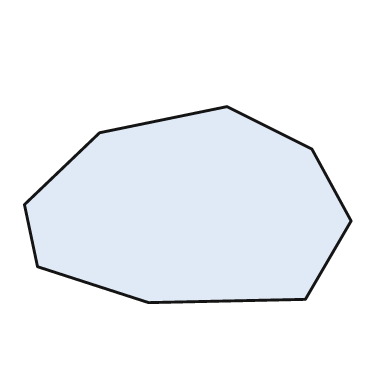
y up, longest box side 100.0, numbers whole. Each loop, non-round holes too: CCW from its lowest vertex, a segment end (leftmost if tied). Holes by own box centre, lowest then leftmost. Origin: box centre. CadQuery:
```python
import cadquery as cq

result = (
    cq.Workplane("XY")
    .moveTo(-12.0, -30.0)
    .lineTo(36.0, -29.0)
    .lineTo(50.0, -5.0)
    .lineTo(38.0, 17.0)
    .lineTo(12.0, 30.0)
    .lineTo(-27.0, 22.0)
    .lineTo(-50.0, 0.0)
    .lineTo(-46.0, -19.0)
    .close()
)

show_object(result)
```